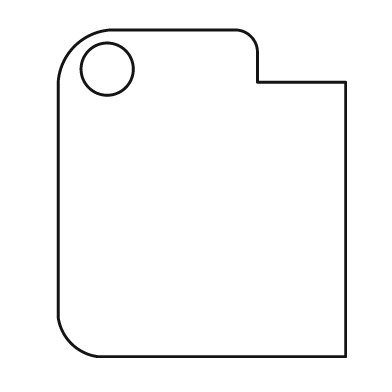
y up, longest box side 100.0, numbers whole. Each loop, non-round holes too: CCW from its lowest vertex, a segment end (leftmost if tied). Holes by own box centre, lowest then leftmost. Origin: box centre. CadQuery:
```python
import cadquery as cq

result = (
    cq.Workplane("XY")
    .moveTo(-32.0, -50.0)
    .lineTo(44.0, -50.0)
    .lineTo(44.0, 34.0)
    .lineTo(17.0, 34.0)
    .lineTo(17.0, 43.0)
    .threePointArc((15.0, 48.0), (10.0, 50.0))
    .lineTo(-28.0, 50.0)
    .threePointArc((-39.0, 45.0), (-44.0, 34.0))
    .lineTo(-44.0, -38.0)
    .threePointArc((-40.0, -46.0), (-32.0, -50.0))
    .close()
    .moveTo(-29.0, 38.0)
    .circle(8.0)
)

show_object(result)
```